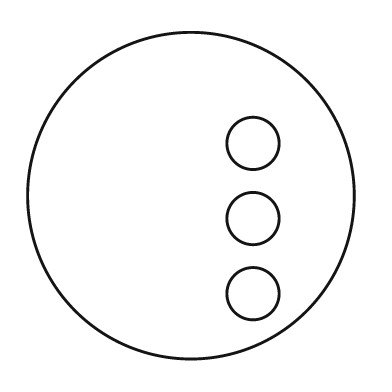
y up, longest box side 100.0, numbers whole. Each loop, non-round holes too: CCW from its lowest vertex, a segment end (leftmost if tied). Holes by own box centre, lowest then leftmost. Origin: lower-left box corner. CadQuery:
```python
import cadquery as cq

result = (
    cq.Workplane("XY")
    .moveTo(50.0, 50.0)
    .circle(50.0)
    .moveTo(69.0, 20.0)
    .circle(8.0)
    .moveTo(69.0, 43.0)
    .circle(8.0)
    .moveTo(69.0, 66.0)
    .circle(8.0)
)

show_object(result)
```